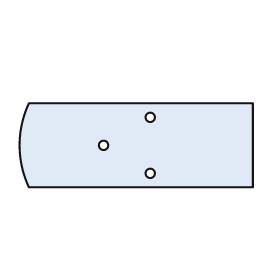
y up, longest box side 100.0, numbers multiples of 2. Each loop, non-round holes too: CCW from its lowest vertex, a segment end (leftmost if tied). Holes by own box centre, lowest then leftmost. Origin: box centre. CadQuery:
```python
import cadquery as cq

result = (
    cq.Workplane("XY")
    .moveTo(-46.0, -18.0)
    .lineTo(50.0, -18.0)
    .lineTo(50.0, 18.0)
    .lineTo(-46.0, 18.0)
    .threePointArc((-50.0, 0.0), (-46.0, -18.0))
    .close()
    .moveTo(6.0, -12.0)
    .circle(2.0)
    .moveTo(-14.0, 0.0)
    .circle(2.0)
    .moveTo(6.0, 12.0)
    .circle(2.0)
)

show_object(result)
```